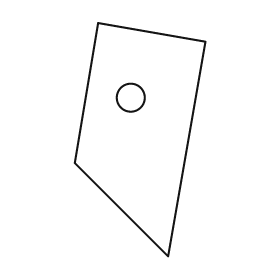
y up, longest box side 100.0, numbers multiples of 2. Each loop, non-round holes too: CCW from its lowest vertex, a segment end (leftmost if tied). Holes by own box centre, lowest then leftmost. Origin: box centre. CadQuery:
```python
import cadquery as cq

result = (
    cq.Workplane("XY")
    .moveTo(12.0, -50.0)
    .lineTo(28.0, 42.0)
    .lineTo(-18.0, 50.0)
    .lineTo(-28.0, -10.0)
    .close()
    .moveTo(-4.0, 18.0)
    .circle(6.0)
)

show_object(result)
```